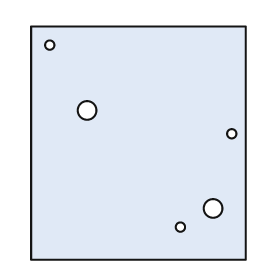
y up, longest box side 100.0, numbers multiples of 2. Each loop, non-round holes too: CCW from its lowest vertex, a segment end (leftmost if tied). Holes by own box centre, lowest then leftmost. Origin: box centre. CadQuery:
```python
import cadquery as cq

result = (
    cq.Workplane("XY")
    .moveTo(-46.0, -50.0)
    .lineTo(46.0, -50.0)
    .lineTo(46.0, 50.0)
    .lineTo(-46.0, 50.0)
    .close()
    .moveTo(18.0, -36.0)
    .circle(2.0)
    .moveTo(32.0, -28.0)
    .circle(4.0)
    .moveTo(40.0, 4.0)
    .circle(2.0)
    .moveTo(-22.0, 14.0)
    .circle(4.0)
    .moveTo(-38.0, 42.0)
    .circle(2.0)
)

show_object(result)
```